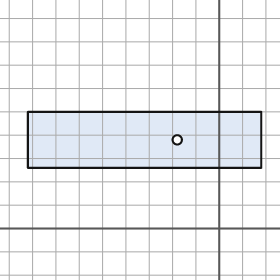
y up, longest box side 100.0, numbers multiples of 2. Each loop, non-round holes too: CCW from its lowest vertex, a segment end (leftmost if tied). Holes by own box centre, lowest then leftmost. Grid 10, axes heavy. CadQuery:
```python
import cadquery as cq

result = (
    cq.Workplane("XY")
    .moveTo(-82.0, 26.0)
    .lineTo(18.0, 26.0)
    .lineTo(18.0, 50.0)
    .lineTo(-82.0, 50.0)
    .close()
    .moveTo(-18.0, 38.0)
    .circle(2.0)
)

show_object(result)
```